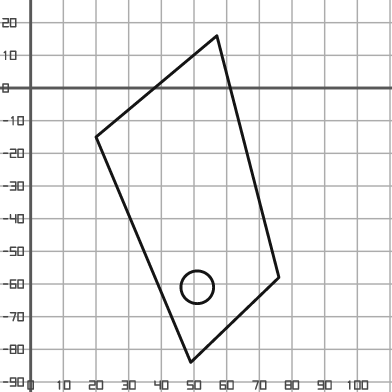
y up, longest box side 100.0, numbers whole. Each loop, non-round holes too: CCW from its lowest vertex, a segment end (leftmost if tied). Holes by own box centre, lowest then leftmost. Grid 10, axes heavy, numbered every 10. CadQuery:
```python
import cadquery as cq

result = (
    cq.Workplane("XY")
    .moveTo(49.0, -84.0)
    .lineTo(76.0, -58.0)
    .lineTo(57.0, 16.0)
    .lineTo(20.0, -15.0)
    .close()
    .moveTo(51.0, -61.0)
    .circle(5.0)
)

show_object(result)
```